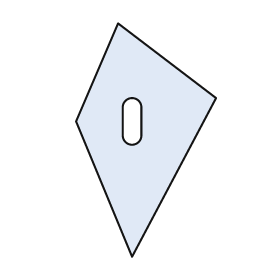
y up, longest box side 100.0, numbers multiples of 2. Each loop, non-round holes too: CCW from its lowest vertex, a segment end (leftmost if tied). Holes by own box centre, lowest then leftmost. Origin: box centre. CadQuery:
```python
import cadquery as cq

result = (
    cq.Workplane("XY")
    .moveTo(-6.0, -50.0)
    .lineTo(30.0, 18.0)
    .lineTo(-12.0, 50.0)
    .lineTo(-30.0, 8.0)
    .close()
    .moveTo(-10.0, 2.0)
    .threePointArc((-6.0, -2.0), (-2.0, 2.0))
    .lineTo(-2.0, 14.0)
    .threePointArc((-6.0, 18.0), (-10.0, 14.0))
    .close()
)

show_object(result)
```